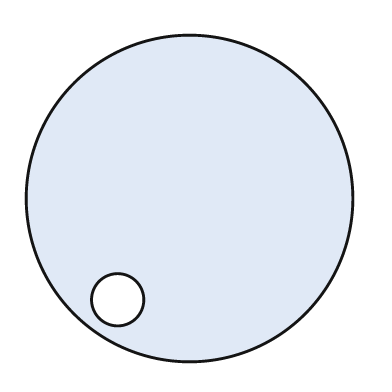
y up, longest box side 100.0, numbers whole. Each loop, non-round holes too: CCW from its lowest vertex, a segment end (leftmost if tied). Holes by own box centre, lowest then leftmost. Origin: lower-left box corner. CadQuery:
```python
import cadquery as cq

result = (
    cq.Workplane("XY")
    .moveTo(50.0, 50.0)
    .circle(50.0)
    .moveTo(28.0, 19.0)
    .circle(8.0)
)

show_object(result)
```